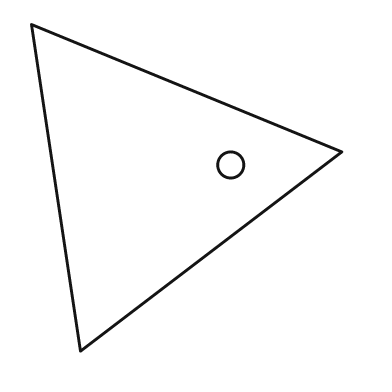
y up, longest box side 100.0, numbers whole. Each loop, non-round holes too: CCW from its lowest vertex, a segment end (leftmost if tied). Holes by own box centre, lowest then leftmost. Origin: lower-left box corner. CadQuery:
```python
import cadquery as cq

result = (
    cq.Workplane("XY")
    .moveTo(15.0, 0.0)
    .lineTo(95.0, 61.0)
    .lineTo(0.0, 100.0)
    .close()
    .moveTo(61.0, 57.0)
    .circle(4.0)
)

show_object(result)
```